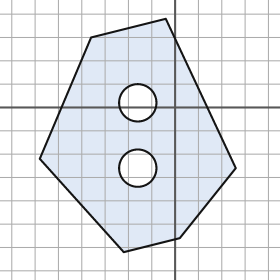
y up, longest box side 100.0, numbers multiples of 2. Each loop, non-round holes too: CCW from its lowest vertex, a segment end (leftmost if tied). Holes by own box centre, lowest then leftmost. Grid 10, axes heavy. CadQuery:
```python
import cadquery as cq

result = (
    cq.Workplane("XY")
    .moveTo(-22.0, -62.0)
    .lineTo(2.0, -56.0)
    .lineTo(26.0, -26.0)
    .lineTo(-4.0, 38.0)
    .lineTo(-36.0, 30.0)
    .lineTo(-58.0, -22.0)
    .close()
    .moveTo(-16.0, -26.0)
    .circle(8.0)
    .moveTo(-16.0, 2.0)
    .circle(8.0)
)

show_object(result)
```